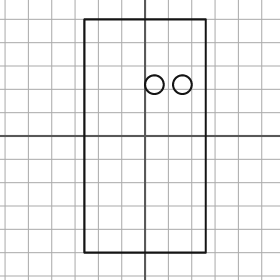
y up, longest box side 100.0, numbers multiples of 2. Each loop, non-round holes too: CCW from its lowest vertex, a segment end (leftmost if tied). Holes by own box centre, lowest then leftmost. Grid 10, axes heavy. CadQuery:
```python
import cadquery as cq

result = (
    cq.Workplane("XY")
    .moveTo(-26.0, -50.0)
    .lineTo(26.0, -50.0)
    .lineTo(26.0, 50.0)
    .lineTo(-26.0, 50.0)
    .close()
    .moveTo(4.0, 22.0)
    .circle(4.0)
    .moveTo(16.0, 22.0)
    .circle(4.0)
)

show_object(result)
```